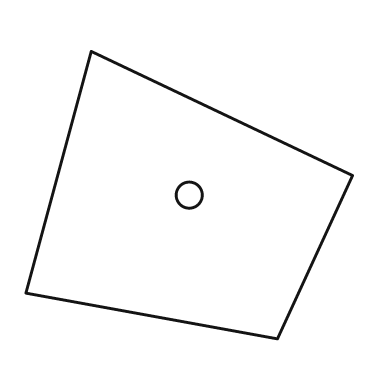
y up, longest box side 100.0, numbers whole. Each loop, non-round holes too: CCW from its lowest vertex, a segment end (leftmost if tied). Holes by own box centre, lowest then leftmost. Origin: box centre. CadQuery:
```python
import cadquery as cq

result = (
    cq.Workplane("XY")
    .moveTo(27.0, -44.0)
    .lineTo(50.0, 6.0)
    .lineTo(-30.0, 44.0)
    .lineTo(-50.0, -30.0)
    .close()
    .moveTo(0.0, 0.0)
    .circle(4.0)
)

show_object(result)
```